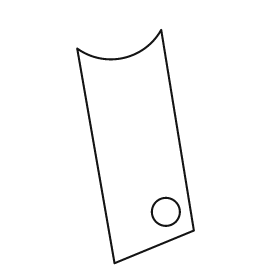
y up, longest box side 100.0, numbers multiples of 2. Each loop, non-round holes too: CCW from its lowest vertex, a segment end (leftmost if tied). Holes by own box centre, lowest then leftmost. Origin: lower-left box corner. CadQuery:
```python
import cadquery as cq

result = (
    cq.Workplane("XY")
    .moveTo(16.0, 0.0)
    .lineTo(50.0, 14.0)
    .lineTo(36.0, 100.0)
    .threePointArc((20.0, 88.0), (0.0, 92.0))
    .close()
    .moveTo(38.0, 22.0)
    .circle(6.0)
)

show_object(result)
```